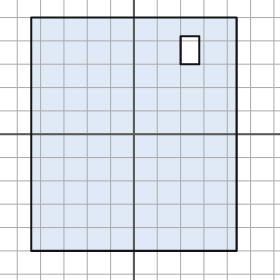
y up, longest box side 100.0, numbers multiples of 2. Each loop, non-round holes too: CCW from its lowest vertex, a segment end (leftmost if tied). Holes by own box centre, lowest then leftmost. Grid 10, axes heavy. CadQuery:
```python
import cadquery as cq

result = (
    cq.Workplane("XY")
    .moveTo(-44.0, -50.0)
    .lineTo(44.0, -50.0)
    .lineTo(44.0, 50.0)
    .lineTo(-44.0, 50.0)
    .close()
    .moveTo(20.0, 30.0)
    .lineTo(28.0, 30.0)
    .lineTo(28.0, 42.0)
    .lineTo(20.0, 42.0)
    .close()
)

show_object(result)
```